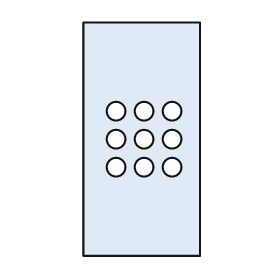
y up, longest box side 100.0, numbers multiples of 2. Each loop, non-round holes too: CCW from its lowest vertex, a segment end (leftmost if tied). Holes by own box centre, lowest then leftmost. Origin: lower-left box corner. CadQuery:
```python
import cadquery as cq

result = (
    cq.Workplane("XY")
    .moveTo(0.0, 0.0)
    .lineTo(50.0, 0.0)
    .lineTo(50.0, 100.0)
    .lineTo(0.0, 100.0)
    .close()
    .moveTo(14.0, 38.0)
    .circle(4.0)
    .moveTo(26.0, 38.0)
    .circle(4.0)
    .moveTo(38.0, 38.0)
    .circle(4.0)
    .moveTo(14.0, 50.0)
    .circle(4.0)
    .moveTo(26.0, 50.0)
    .circle(4.0)
    .moveTo(38.0, 50.0)
    .circle(4.0)
    .moveTo(14.0, 62.0)
    .circle(4.0)
    .moveTo(26.0, 62.0)
    .circle(4.0)
    .moveTo(38.0, 62.0)
    .circle(4.0)
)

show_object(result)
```